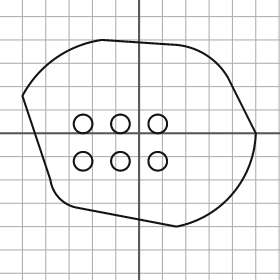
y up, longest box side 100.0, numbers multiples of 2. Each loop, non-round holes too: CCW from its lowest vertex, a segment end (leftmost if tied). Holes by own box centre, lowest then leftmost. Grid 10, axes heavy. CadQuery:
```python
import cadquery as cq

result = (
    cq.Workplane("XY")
    .moveTo(16.0, -40.0)
    .threePointArc((40.0, -26.0), (50.0, 0.0))
    .lineTo(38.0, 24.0)
    .threePointArc((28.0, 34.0), (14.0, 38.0))
    .lineTo(-16.0, 40.0)
    .threePointArc((-36.0, 32.0), (-50.0, 16.0))
    .lineTo(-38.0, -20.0)
    .threePointArc((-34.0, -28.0), (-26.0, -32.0))
    .close()
    .moveTo(-24.0, -12.0)
    .circle(4.0)
    .moveTo(-8.0, -12.0)
    .circle(4.0)
    .moveTo(8.0, -12.0)
    .circle(4.0)
    .moveTo(-24.0, 4.0)
    .circle(4.0)
    .moveTo(-8.0, 4.0)
    .circle(4.0)
    .moveTo(8.0, 4.0)
    .circle(4.0)
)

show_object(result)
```